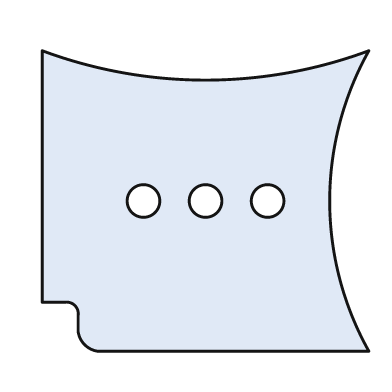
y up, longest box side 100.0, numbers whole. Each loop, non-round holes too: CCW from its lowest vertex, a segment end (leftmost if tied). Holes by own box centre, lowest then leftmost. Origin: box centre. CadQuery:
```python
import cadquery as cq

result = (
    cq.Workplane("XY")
    .moveTo(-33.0, -46.0)
    .lineTo(50.0, -46.0)
    .threePointArc((38.0, 0.0), (50.0, 46.0))
    .threePointArc((0.0, 37.0), (-50.0, 46.0))
    .lineTo(-50.0, -31.0)
    .lineTo(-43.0, -31.0)
    .threePointArc((-40.0, -32.0), (-39.0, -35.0))
    .lineTo(-39.0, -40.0)
    .threePointArc((-37.0, -44.0), (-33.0, -46.0))
    .close()
    .moveTo(-19.0, 0.0)
    .circle(5.0)
    .moveTo(0.0, 0.0)
    .circle(5.0)
    .moveTo(19.0, 0.0)
    .circle(5.0)
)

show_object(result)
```